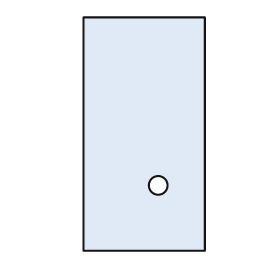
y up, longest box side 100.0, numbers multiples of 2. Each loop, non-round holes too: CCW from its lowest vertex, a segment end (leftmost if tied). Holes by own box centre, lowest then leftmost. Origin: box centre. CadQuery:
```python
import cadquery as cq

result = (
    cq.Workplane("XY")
    .moveTo(-26.0, -50.0)
    .lineTo(26.0, -50.0)
    .lineTo(26.0, 50.0)
    .lineTo(-26.0, 50.0)
    .close()
    .moveTo(6.0, -22.0)
    .circle(4.0)
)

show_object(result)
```